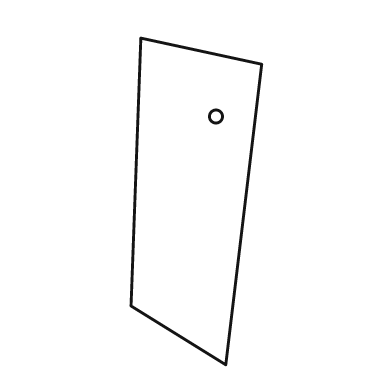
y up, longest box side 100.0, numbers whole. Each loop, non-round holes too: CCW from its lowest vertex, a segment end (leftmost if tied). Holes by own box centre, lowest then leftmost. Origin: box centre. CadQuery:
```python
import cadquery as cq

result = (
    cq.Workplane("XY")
    .moveTo(9.0, -50.0)
    .lineTo(20.0, 42.0)
    .lineTo(-17.0, 50.0)
    .lineTo(-20.0, -32.0)
    .close()
    .moveTo(6.0, 26.0)
    .circle(2.0)
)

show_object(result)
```